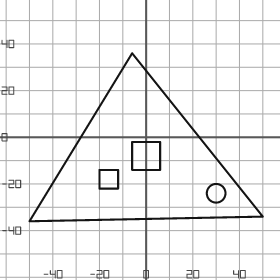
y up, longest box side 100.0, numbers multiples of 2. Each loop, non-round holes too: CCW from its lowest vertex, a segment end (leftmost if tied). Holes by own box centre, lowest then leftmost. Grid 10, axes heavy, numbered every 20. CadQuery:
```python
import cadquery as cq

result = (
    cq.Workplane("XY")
    .moveTo(-50.0, -36.0)
    .lineTo(50.0, -34.0)
    .lineTo(-6.0, 36.0)
    .close()
    .moveTo(30.0, -24.0)
    .circle(4.0)
    .moveTo(-20.0, -22.0)
    .lineTo(-12.0, -22.0)
    .lineTo(-12.0, -14.0)
    .lineTo(-20.0, -14.0)
    .close()
    .moveTo(-6.0, -14.0)
    .lineTo(6.0, -14.0)
    .lineTo(6.0, -2.0)
    .lineTo(-6.0, -2.0)
    .close()
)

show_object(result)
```